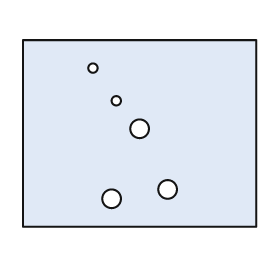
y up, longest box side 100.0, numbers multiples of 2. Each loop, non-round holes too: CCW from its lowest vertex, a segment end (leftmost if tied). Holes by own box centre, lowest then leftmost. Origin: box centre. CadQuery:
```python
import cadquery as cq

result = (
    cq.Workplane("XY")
    .moveTo(-50.0, -40.0)
    .lineTo(50.0, -40.0)
    .lineTo(50.0, 40.0)
    .lineTo(-50.0, 40.0)
    .close()
    .moveTo(-12.0, -28.0)
    .circle(4.0)
    .moveTo(12.0, -24.0)
    .circle(4.0)
    .moveTo(0.0, 2.0)
    .circle(4.0)
    .moveTo(-10.0, 14.0)
    .circle(2.0)
    .moveTo(-20.0, 28.0)
    .circle(2.0)
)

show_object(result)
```